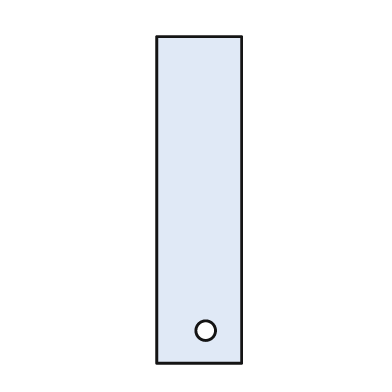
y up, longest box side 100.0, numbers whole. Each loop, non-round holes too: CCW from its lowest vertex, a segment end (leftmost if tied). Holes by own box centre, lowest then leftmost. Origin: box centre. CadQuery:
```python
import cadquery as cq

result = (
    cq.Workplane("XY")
    .moveTo(-13.0, -50.0)
    .lineTo(13.0, -50.0)
    .lineTo(13.0, 50.0)
    .lineTo(-13.0, 50.0)
    .close()
    .moveTo(2.0, -40.0)
    .circle(3.0)
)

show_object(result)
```